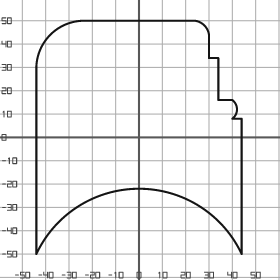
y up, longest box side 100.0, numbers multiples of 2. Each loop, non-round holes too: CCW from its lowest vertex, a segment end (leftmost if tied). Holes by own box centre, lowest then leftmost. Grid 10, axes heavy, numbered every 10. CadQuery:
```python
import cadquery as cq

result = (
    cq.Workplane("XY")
    .moveTo(-44.0, -50.0)
    .threePointArc((0.0, -22.0), (44.0, -50.0))
    .lineTo(44.0, 8.0)
    .lineTo(40.0, 8.0)
    .threePointArc((42.0, 12.0), (40.0, 16.0))
    .lineTo(34.0, 16.0)
    .lineTo(34.0, 34.0)
    .lineTo(30.0, 34.0)
    .lineTo(30.0, 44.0)
    .threePointArc((28.0, 48.0), (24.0, 50.0))
    .lineTo(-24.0, 50.0)
    .threePointArc((-38.0, 44.0), (-44.0, 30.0))
    .close()
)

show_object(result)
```